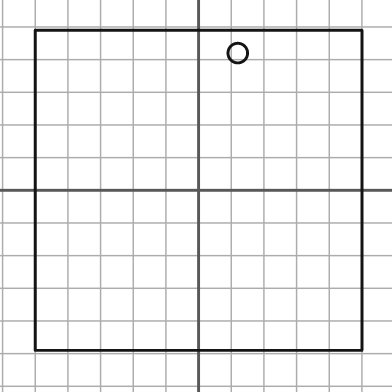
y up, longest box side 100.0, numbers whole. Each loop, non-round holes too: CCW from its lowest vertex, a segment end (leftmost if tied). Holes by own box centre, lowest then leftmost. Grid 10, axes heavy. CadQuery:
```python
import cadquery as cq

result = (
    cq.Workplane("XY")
    .moveTo(-50.0, -49.0)
    .lineTo(50.0, -49.0)
    .lineTo(50.0, 49.0)
    .lineTo(-50.0, 49.0)
    .close()
    .moveTo(12.0, 42.0)
    .circle(3.0)
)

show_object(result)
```